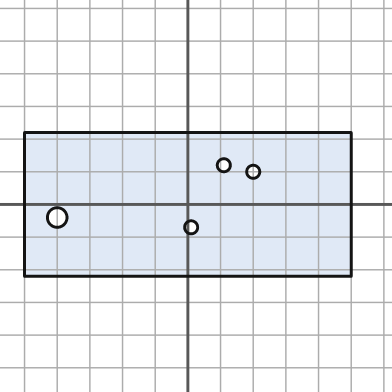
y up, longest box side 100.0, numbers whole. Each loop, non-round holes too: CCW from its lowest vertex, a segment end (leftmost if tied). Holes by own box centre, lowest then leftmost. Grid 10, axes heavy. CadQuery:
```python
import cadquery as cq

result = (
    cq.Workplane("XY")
    .moveTo(-50.0, -22.0)
    .lineTo(50.0, -22.0)
    .lineTo(50.0, 22.0)
    .lineTo(-50.0, 22.0)
    .close()
    .moveTo(1.0, -7.0)
    .circle(2.0)
    .moveTo(-40.0, -4.0)
    .circle(3.0)
    .moveTo(20.0, 10.0)
    .circle(2.0)
    .moveTo(11.0, 12.0)
    .circle(2.0)
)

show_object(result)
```